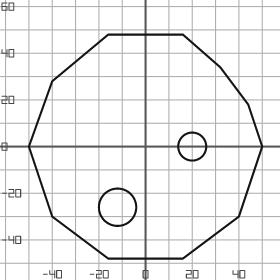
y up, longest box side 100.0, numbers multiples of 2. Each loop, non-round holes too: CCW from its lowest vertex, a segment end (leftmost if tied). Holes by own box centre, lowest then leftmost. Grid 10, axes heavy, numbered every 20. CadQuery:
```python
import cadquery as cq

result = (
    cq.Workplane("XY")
    .moveTo(-16.0, -48.0)
    .lineTo(16.0, -48.0)
    .lineTo(40.0, -30.0)
    .lineTo(50.0, 0.0)
    .lineTo(44.0, 18.0)
    .lineTo(32.0, 34.0)
    .lineTo(16.0, 48.0)
    .lineTo(-16.0, 48.0)
    .lineTo(-40.0, 28.0)
    .lineTo(-50.0, 0.0)
    .lineTo(-40.0, -30.0)
    .close()
    .moveTo(-12.0, -26.0)
    .circle(8.0)
    .moveTo(20.0, 0.0)
    .circle(6.0)
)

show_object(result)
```